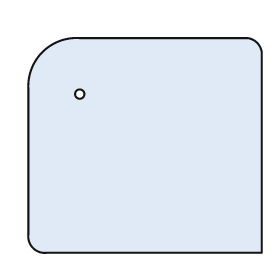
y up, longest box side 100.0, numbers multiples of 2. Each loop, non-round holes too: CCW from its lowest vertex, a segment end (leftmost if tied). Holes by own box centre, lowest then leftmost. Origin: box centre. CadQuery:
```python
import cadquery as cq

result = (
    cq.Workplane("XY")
    .moveTo(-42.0, -46.0)
    .lineTo(50.0, -46.0)
    .lineTo(50.0, 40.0)
    .threePointArc((48.0, 44.0), (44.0, 46.0))
    .lineTo(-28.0, 46.0)
    .threePointArc((-44.0, 40.0), (-50.0, 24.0))
    .lineTo(-50.0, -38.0)
    .threePointArc((-48.0, -44.0), (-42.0, -46.0))
    .close()
    .moveTo(-28.0, 22.0)
    .circle(2.0)
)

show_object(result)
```